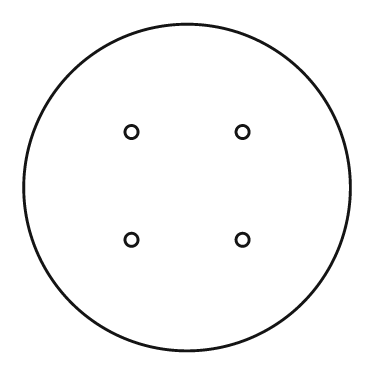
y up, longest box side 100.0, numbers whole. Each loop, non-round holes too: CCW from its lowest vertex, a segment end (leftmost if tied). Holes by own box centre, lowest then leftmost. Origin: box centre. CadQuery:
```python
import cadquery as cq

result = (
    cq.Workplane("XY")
    .moveTo(0.0, 0.0)
    .circle(50.0)
    .moveTo(-17.0, -16.0)
    .circle(2.0)
    .moveTo(17.0, -16.0)
    .circle(2.0)
    .moveTo(-17.0, 17.0)
    .circle(2.0)
    .moveTo(17.0, 17.0)
    .circle(2.0)
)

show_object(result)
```